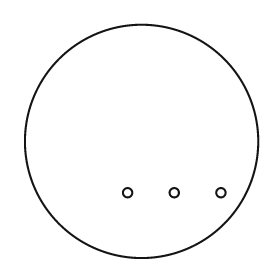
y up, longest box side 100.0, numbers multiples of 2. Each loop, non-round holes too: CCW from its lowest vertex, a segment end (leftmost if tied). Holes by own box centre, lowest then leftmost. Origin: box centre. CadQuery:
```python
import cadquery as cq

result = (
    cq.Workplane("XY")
    .moveTo(0.0, 0.0)
    .circle(50.0)
    .moveTo(-6.0, -22.0)
    .circle(2.0)
    .moveTo(14.0, -22.0)
    .circle(2.0)
    .moveTo(34.0, -22.0)
    .circle(2.0)
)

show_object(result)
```